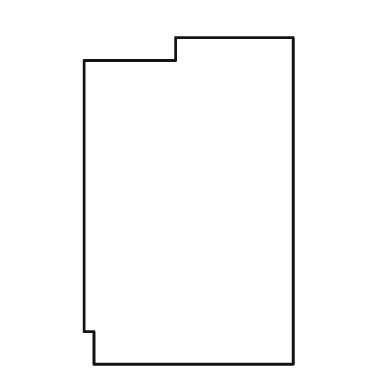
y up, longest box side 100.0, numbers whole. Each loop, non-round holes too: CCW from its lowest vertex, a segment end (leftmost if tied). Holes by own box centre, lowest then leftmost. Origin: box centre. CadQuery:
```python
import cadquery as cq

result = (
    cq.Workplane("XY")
    .moveTo(-29.0, -50.0)
    .lineTo(32.0, -50.0)
    .lineTo(32.0, 50.0)
    .lineTo(-4.0, 50.0)
    .lineTo(-4.0, 43.0)
    .lineTo(-32.0, 43.0)
    .lineTo(-32.0, -40.0)
    .lineTo(-29.0, -40.0)
    .close()
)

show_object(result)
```